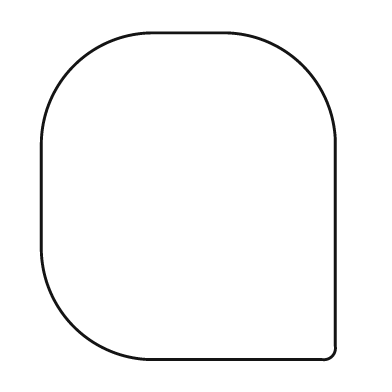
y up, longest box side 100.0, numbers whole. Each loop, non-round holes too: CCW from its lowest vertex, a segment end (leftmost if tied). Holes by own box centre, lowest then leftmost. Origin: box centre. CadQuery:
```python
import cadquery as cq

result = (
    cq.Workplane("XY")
    .moveTo(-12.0, -50.0)
    .lineTo(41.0, -50.0)
    .threePointArc((44.0, -49.0), (45.0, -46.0))
    .lineTo(45.0, 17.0)
    .threePointArc((35.0, 40.0), (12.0, 50.0))
    .lineTo(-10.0, 50.0)
    .threePointArc((-35.0, 40.0), (-45.0, 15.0))
    .lineTo(-45.0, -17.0)
    .threePointArc((-35.0, -40.0), (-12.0, -50.0))
    .close()
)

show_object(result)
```